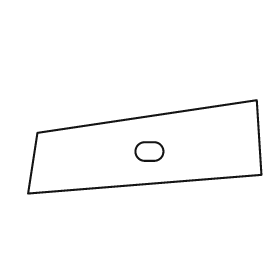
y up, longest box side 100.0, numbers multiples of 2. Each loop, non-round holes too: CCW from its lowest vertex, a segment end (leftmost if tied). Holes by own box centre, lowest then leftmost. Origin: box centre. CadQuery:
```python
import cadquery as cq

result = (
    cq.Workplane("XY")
    .moveTo(-50.0, -20.0)
    .lineTo(50.0, -12.0)
    .lineTo(48.0, 20.0)
    .lineTo(-46.0, 6.0)
    .close()
    .moveTo(0.0, -6.0)
    .lineTo(4.0, -6.0)
    .threePointArc((8.0, -2.0), (4.0, 2.0))
    .lineTo(0.0, 2.0)
    .threePointArc((-4.0, -2.0), (0.0, -6.0))
    .close()
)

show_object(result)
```